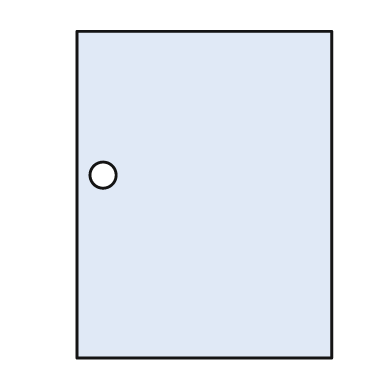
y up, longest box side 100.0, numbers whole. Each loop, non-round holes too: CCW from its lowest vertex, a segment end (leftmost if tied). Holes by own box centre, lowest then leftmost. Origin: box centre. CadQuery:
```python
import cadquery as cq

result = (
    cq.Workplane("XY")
    .moveTo(-39.0, -50.0)
    .lineTo(39.0, -50.0)
    .lineTo(39.0, 50.0)
    .lineTo(-39.0, 50.0)
    .close()
    .moveTo(-31.0, 6.0)
    .circle(4.0)
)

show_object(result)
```